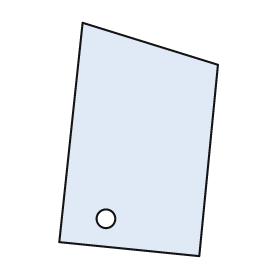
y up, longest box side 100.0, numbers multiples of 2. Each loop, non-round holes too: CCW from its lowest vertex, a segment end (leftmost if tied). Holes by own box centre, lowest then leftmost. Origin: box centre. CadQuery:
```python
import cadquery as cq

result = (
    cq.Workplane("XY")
    .moveTo(26.0, -50.0)
    .lineTo(34.0, 32.0)
    .lineTo(-24.0, 50.0)
    .lineTo(-34.0, -44.0)
    .close()
    .moveTo(-14.0, -34.0)
    .circle(4.0)
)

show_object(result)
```